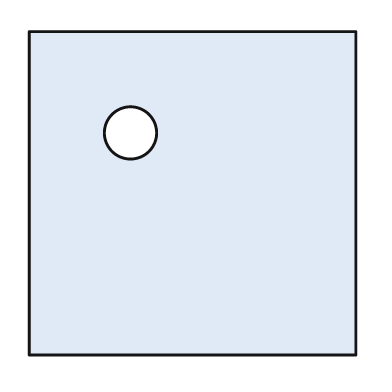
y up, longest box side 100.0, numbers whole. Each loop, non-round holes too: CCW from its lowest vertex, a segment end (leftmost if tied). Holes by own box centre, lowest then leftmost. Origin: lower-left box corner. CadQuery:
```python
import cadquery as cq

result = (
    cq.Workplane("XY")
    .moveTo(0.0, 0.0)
    .lineTo(100.0, 0.0)
    .lineTo(100.0, 99.0)
    .lineTo(0.0, 99.0)
    .close()
    .moveTo(31.0, 68.0)
    .circle(8.0)
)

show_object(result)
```